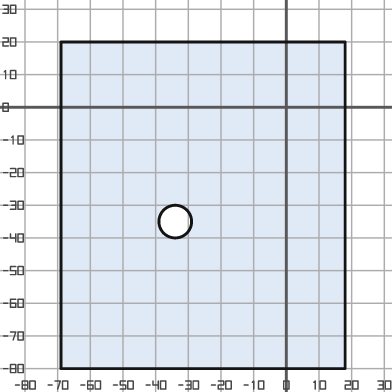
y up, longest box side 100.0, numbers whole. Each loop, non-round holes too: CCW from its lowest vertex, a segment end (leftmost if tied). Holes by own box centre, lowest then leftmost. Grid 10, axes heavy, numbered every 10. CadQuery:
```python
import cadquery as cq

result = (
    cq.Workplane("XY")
    .moveTo(-69.0, -80.0)
    .lineTo(18.0, -80.0)
    .lineTo(18.0, 20.0)
    .lineTo(-69.0, 20.0)
    .close()
    .moveTo(-34.0, -35.0)
    .circle(5.0)
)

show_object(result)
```